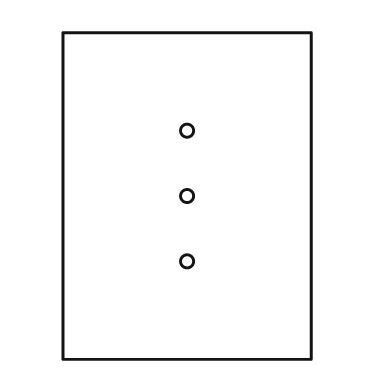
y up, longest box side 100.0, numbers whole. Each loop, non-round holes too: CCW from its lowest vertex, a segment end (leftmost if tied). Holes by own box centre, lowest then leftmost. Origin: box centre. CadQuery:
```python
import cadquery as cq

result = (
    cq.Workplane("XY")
    .moveTo(-38.0, -50.0)
    .lineTo(38.0, -50.0)
    .lineTo(38.0, 50.0)
    .lineTo(-38.0, 50.0)
    .close()
    .moveTo(0.0, -20.0)
    .circle(2.0)
    .moveTo(0.0, 0.0)
    .circle(2.0)
    .moveTo(0.0, 20.0)
    .circle(2.0)
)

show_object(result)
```